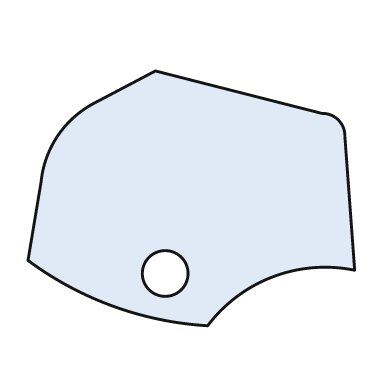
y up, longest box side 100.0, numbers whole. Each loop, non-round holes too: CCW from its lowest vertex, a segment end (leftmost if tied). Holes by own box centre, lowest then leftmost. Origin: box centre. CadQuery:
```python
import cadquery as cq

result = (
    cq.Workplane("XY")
    .moveTo(5.0, -39.0)
    .threePointArc((25.0, -24.0), (50.0, -22.0))
    .lineTo(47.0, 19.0)
    .threePointArc((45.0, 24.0), (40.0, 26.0))
    .lineTo(-11.0, 39.0)
    .lineTo(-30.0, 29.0)
    .threePointArc((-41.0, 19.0), (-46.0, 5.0))
    .lineTo(-50.0, -19.0)
    .threePointArc((-24.0, -33.0), (5.0, -39.0))
    .close()
    .moveTo(-8.0, -23.0)
    .circle(7.0)
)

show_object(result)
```